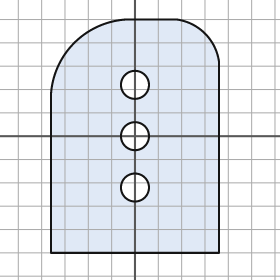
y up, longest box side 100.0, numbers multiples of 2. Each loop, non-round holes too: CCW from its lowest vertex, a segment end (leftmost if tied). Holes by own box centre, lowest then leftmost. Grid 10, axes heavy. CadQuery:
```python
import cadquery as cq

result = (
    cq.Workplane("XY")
    .moveTo(-36.0, -50.0)
    .lineTo(36.0, -50.0)
    .lineTo(36.0, 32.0)
    .threePointArc((30.0, 44.0), (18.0, 50.0))
    .lineTo(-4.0, 50.0)
    .threePointArc((-26.0, 40.0), (-36.0, 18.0))
    .close()
    .moveTo(0.0, -22.0)
    .circle(6.0)
    .moveTo(0.0, 0.0)
    .circle(6.0)
    .moveTo(0.0, 22.0)
    .circle(6.0)
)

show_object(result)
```